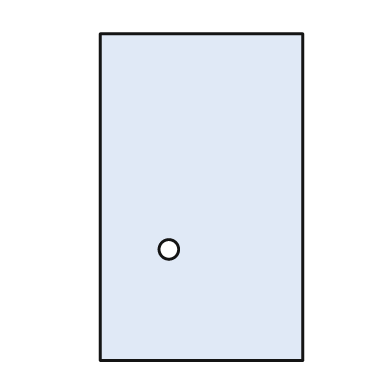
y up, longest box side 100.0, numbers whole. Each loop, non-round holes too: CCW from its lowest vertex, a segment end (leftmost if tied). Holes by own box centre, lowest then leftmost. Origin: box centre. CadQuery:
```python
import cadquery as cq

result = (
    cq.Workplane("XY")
    .moveTo(-31.0, -50.0)
    .lineTo(31.0, -50.0)
    .lineTo(31.0, 50.0)
    .lineTo(-31.0, 50.0)
    .close()
    .moveTo(-10.0, -16.0)
    .circle(3.0)
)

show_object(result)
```